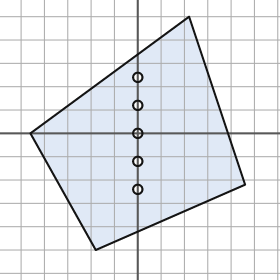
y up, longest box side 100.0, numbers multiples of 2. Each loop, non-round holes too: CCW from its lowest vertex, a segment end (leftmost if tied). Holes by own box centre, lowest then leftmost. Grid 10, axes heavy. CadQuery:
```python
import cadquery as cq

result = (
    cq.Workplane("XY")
    .moveTo(-18.0, -50.0)
    .lineTo(46.0, -22.0)
    .lineTo(22.0, 50.0)
    .lineTo(-46.0, 0.0)
    .close()
    .moveTo(0.0, -24.0)
    .circle(2.0)
    .moveTo(0.0, -12.0)
    .circle(2.0)
    .moveTo(0.0, 0.0)
    .circle(2.0)
    .moveTo(0.0, 12.0)
    .circle(2.0)
    .moveTo(0.0, 24.0)
    .circle(2.0)
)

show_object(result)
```